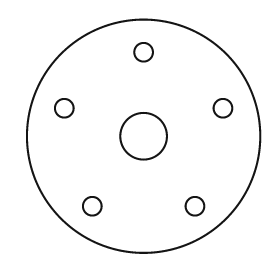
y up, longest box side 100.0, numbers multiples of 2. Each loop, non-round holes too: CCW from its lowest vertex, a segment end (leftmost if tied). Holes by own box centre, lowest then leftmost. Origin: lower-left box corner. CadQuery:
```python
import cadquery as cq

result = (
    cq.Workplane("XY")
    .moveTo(50.0, 50.0)
    .circle(50.0)
    .moveTo(28.0, 20.0)
    .circle(4.0)
    .moveTo(72.0, 20.0)
    .circle(4.0)
    .moveTo(50.0, 50.0)
    .circle(10.0)
    .moveTo(16.0, 62.0)
    .circle(4.0)
    .moveTo(84.0, 62.0)
    .circle(4.0)
    .moveTo(50.0, 86.0)
    .circle(4.0)
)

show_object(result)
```